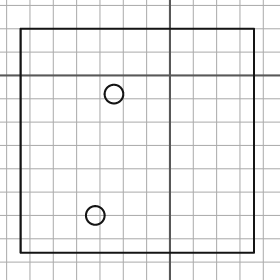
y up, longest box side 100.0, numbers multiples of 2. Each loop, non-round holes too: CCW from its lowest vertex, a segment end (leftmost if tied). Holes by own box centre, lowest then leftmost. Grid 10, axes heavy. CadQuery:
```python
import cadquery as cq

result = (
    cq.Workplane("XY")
    .moveTo(-64.0, -76.0)
    .lineTo(36.0, -76.0)
    .lineTo(36.0, 20.0)
    .lineTo(-64.0, 20.0)
    .close()
    .moveTo(-32.0, -60.0)
    .circle(4.0)
    .moveTo(-24.0, -8.0)
    .circle(4.0)
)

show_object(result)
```